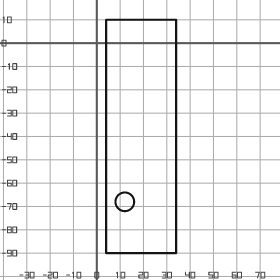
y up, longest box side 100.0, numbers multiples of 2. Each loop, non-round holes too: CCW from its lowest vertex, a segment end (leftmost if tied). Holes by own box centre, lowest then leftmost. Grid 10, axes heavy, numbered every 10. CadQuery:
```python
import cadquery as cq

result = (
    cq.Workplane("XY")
    .moveTo(4.0, -90.0)
    .lineTo(34.0, -90.0)
    .lineTo(34.0, 10.0)
    .lineTo(4.0, 10.0)
    .close()
    .moveTo(12.0, -68.0)
    .circle(4.0)
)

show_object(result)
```